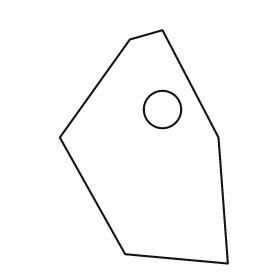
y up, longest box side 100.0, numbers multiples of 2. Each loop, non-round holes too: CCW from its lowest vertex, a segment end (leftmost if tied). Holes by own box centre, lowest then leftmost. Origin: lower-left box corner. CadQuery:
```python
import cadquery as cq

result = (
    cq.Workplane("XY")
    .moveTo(72.0, 0.0)
    .lineTo(68.0, 54.0)
    .lineTo(44.0, 100.0)
    .lineTo(30.0, 96.0)
    .lineTo(0.0, 54.0)
    .lineTo(28.0, 4.0)
    .close()
    .moveTo(44.0, 66.0)
    .circle(8.0)
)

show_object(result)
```